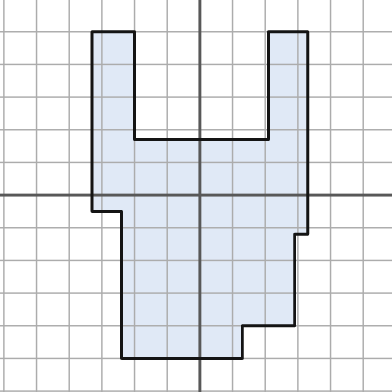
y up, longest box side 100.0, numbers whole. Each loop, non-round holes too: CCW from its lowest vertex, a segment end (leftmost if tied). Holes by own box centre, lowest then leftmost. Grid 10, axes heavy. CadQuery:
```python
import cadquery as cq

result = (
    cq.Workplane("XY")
    .moveTo(-24.0, -50.0)
    .lineTo(13.0, -50.0)
    .lineTo(13.0, -40.0)
    .lineTo(29.0, -40.0)
    .lineTo(29.0, -12.0)
    .lineTo(33.0, -12.0)
    .lineTo(33.0, 50.0)
    .lineTo(21.0, 50.0)
    .lineTo(21.0, 17.0)
    .lineTo(-20.0, 17.0)
    .lineTo(-20.0, 50.0)
    .lineTo(-33.0, 50.0)
    .lineTo(-33.0, -5.0)
    .lineTo(-24.0, -5.0)
    .close()
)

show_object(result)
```